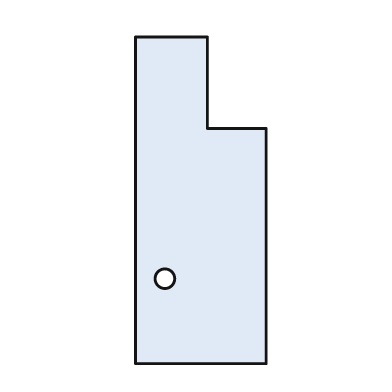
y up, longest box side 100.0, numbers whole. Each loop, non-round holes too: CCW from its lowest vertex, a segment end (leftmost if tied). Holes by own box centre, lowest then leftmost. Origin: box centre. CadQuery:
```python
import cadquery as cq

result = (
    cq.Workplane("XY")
    .moveTo(-20.0, -50.0)
    .lineTo(20.0, -50.0)
    .lineTo(20.0, 22.0)
    .lineTo(2.0, 22.0)
    .lineTo(2.0, 50.0)
    .lineTo(-20.0, 50.0)
    .close()
    .moveTo(-11.0, -24.0)
    .circle(3.0)
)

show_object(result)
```